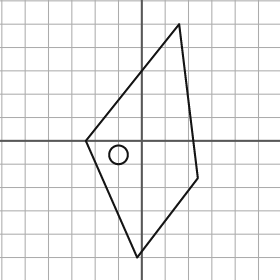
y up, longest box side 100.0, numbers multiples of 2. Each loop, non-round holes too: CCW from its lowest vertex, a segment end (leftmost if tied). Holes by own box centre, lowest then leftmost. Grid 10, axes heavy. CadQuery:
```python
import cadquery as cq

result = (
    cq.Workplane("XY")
    .moveTo(-2.0, -50.0)
    .lineTo(24.0, -16.0)
    .lineTo(16.0, 50.0)
    .lineTo(-24.0, 0.0)
    .close()
    .moveTo(-10.0, -6.0)
    .circle(4.0)
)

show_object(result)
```